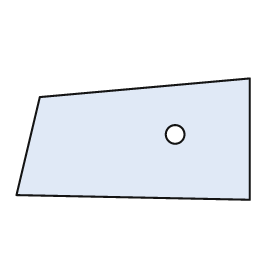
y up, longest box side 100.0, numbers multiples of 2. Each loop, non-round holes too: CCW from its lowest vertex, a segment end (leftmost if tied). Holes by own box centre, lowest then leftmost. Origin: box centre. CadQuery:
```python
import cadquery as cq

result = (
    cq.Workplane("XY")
    .moveTo(50.0, -26.0)
    .lineTo(50.0, 26.0)
    .lineTo(-40.0, 18.0)
    .lineTo(-50.0, -24.0)
    .close()
    .moveTo(18.0, 2.0)
    .circle(4.0)
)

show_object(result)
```